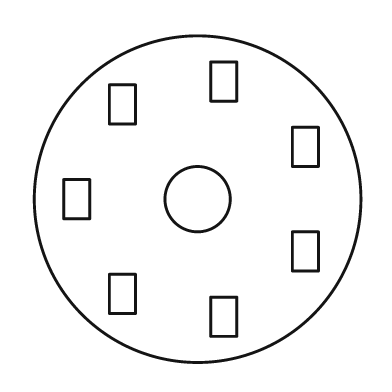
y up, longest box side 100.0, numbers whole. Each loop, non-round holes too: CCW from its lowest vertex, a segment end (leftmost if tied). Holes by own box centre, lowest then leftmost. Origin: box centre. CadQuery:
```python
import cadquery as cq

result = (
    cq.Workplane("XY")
    .moveTo(0.0, 0.0)
    .circle(50.0)
    .moveTo(4.0, -42.0)
    .lineTo(12.0, -42.0)
    .lineTo(12.0, -30.0)
    .lineTo(4.0, -30.0)
    .close()
    .moveTo(-27.0, -35.0)
    .lineTo(-19.0, -35.0)
    .lineTo(-19.0, -23.0)
    .lineTo(-27.0, -23.0)
    .close()
    .moveTo(29.0, -22.0)
    .lineTo(37.0, -22.0)
    .lineTo(37.0, -10.0)
    .lineTo(29.0, -10.0)
    .close()
    .moveTo(-41.0, -6.0)
    .lineTo(-33.0, -6.0)
    .lineTo(-33.0, 6.0)
    .lineTo(-41.0, 6.0)
    .close()
    .moveTo(0.0, 0.0)
    .circle(10.0)
    .moveTo(29.0, 10.0)
    .lineTo(37.0, 10.0)
    .lineTo(37.0, 22.0)
    .lineTo(29.0, 22.0)
    .close()
    .moveTo(-27.0, 23.0)
    .lineTo(-19.0, 23.0)
    .lineTo(-19.0, 35.0)
    .lineTo(-27.0, 35.0)
    .close()
    .moveTo(4.0, 30.0)
    .lineTo(12.0, 30.0)
    .lineTo(12.0, 42.0)
    .lineTo(4.0, 42.0)
    .close()
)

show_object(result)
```